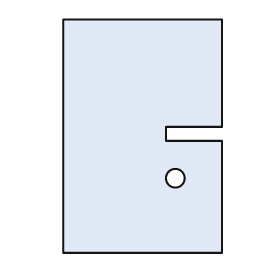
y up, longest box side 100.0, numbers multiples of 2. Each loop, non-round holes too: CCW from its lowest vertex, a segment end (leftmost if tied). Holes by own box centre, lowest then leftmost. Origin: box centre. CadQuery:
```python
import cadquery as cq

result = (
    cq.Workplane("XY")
    .moveTo(-34.0, -50.0)
    .lineTo(34.0, -50.0)
    .lineTo(34.0, -2.0)
    .lineTo(10.0, -2.0)
    .lineTo(10.0, 4.0)
    .lineTo(34.0, 4.0)
    .lineTo(34.0, 50.0)
    .lineTo(-34.0, 50.0)
    .close()
    .moveTo(14.0, -18.0)
    .circle(4.0)
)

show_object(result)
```